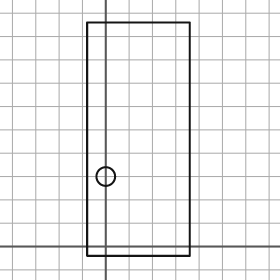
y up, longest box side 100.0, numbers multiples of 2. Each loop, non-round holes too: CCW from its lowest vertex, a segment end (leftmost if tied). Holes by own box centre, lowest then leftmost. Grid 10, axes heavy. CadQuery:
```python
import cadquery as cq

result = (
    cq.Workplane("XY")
    .moveTo(-8.0, -4.0)
    .lineTo(36.0, -4.0)
    .lineTo(36.0, 96.0)
    .lineTo(-8.0, 96.0)
    .close()
    .moveTo(0.0, 30.0)
    .circle(4.0)
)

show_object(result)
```